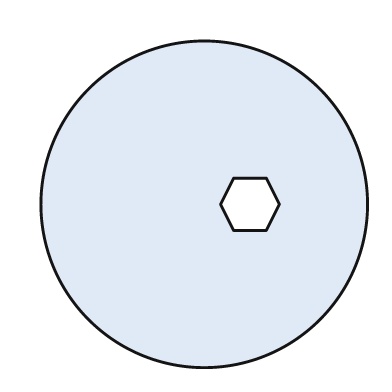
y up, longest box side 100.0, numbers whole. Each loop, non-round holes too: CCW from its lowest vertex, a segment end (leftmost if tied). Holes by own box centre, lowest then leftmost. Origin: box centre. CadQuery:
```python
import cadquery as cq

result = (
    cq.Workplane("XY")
    .moveTo(0.0, 0.0)
    .circle(50.0)
    .moveTo(9.0, -8.0)
    .lineTo(19.0, -8.0)
    .lineTo(23.0, 0.0)
    .lineTo(19.0, 8.0)
    .lineTo(9.0, 8.0)
    .lineTo(5.0, 0.0)
    .close()
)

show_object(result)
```